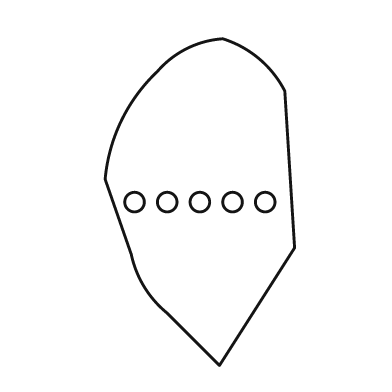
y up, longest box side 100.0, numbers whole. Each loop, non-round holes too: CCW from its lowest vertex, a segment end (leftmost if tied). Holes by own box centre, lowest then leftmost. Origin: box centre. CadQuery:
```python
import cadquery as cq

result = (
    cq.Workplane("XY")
    .moveTo(6.0, -50.0)
    .lineTo(29.0, -14.0)
    .lineTo(26.0, 34.0)
    .threePointArc((18.0, 44.0), (7.0, 50.0))
    .threePointArc((-4.0, 47.0), (-13.0, 40.0))
    .threePointArc((-24.0, 25.0), (-29.0, 7.0))
    .lineTo(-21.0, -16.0)
    .threePointArc((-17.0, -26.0), (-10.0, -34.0))
    .close()
    .moveTo(-20.0, 0.0)
    .circle(3.0)
    .moveTo(-10.0, 0.0)
    .circle(3.0)
    .moveTo(0.0, 0.0)
    .circle(3.0)
    .moveTo(10.0, 0.0)
    .circle(3.0)
    .moveTo(20.0, 0.0)
    .circle(3.0)
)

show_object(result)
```